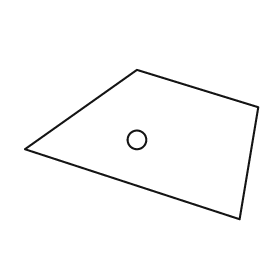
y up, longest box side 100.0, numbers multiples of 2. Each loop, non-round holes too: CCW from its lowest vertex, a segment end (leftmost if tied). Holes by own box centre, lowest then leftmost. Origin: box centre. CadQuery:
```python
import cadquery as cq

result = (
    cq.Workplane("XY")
    .moveTo(42.0, -32.0)
    .lineTo(50.0, 16.0)
    .lineTo(-2.0, 32.0)
    .lineTo(-50.0, -2.0)
    .close()
    .moveTo(-2.0, 2.0)
    .circle(4.0)
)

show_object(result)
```